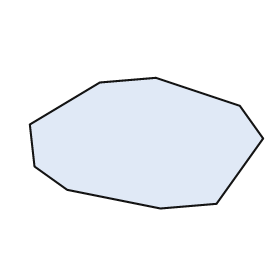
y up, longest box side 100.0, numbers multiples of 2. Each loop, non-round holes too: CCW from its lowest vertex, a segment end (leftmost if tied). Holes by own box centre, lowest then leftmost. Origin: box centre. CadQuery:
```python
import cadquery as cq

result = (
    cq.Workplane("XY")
    .moveTo(6.0, -28.0)
    .lineTo(30.0, -26.0)
    .lineTo(50.0, 2.0)
    .lineTo(40.0, 16.0)
    .lineTo(4.0, 28.0)
    .lineTo(-20.0, 26.0)
    .lineTo(-50.0, 8.0)
    .lineTo(-48.0, -10.0)
    .lineTo(-34.0, -20.0)
    .close()
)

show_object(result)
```